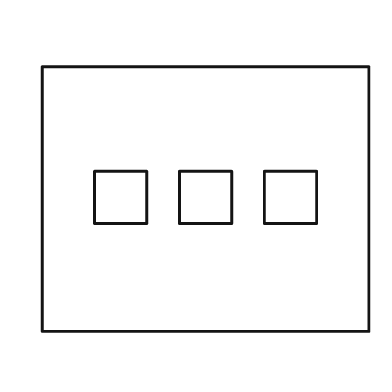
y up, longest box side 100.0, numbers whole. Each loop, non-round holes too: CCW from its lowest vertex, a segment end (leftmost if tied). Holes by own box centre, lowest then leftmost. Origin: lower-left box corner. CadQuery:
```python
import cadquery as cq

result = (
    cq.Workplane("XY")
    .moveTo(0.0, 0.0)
    .lineTo(100.0, 0.0)
    .lineTo(100.0, 81.0)
    .lineTo(0.0, 81.0)
    .close()
    .moveTo(16.0, 33.0)
    .lineTo(32.0, 33.0)
    .lineTo(32.0, 49.0)
    .lineTo(16.0, 49.0)
    .close()
    .moveTo(42.0, 33.0)
    .lineTo(58.0, 33.0)
    .lineTo(58.0, 49.0)
    .lineTo(42.0, 49.0)
    .close()
    .moveTo(68.0, 33.0)
    .lineTo(84.0, 33.0)
    .lineTo(84.0, 49.0)
    .lineTo(68.0, 49.0)
    .close()
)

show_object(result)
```